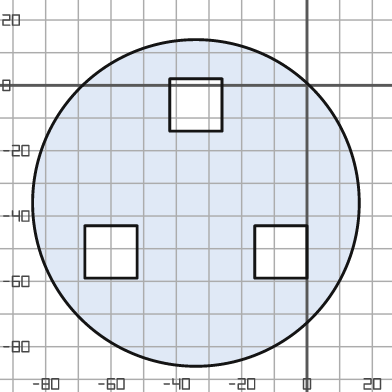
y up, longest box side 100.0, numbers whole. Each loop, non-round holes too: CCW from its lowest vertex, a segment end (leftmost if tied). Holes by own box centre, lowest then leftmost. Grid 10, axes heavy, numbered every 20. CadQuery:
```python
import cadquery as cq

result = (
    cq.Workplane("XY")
    .moveTo(-34.0, -36.0)
    .circle(50.0)
    .moveTo(-68.0, -59.0)
    .lineTo(-52.0, -59.0)
    .lineTo(-52.0, -43.0)
    .lineTo(-68.0, -43.0)
    .close()
    .moveTo(-16.0, -59.0)
    .lineTo(0.0, -59.0)
    .lineTo(0.0, -43.0)
    .lineTo(-16.0, -43.0)
    .close()
    .moveTo(-42.0, -14.0)
    .lineTo(-26.0, -14.0)
    .lineTo(-26.0, 2.0)
    .lineTo(-42.0, 2.0)
    .close()
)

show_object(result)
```